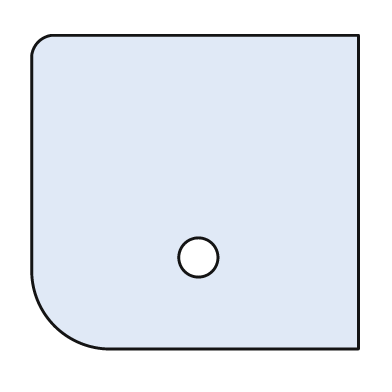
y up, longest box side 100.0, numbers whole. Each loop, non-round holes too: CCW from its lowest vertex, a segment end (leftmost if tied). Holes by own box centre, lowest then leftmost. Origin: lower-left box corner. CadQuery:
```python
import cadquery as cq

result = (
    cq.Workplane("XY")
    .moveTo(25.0, 0.0)
    .lineTo(100.0, 0.0)
    .lineTo(100.0, 96.0)
    .lineTo(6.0, 96.0)
    .threePointArc((2.0, 94.0), (0.0, 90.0))
    .lineTo(0.0, 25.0)
    .threePointArc((7.0, 7.0), (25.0, 0.0))
    .close()
    .moveTo(51.0, 28.0)
    .circle(6.0)
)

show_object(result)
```